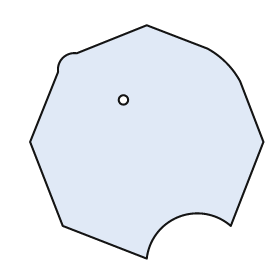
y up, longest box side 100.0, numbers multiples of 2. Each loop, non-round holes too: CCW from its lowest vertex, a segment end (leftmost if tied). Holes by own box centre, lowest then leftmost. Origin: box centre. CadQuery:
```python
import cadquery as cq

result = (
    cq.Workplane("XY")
    .moveTo(0.0, -50.0)
    .threePointArc((14.0, -32.0), (36.0, -36.0))
    .lineTo(50.0, 0.0)
    .lineTo(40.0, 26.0)
    .threePointArc((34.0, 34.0), (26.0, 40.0))
    .lineTo(0.0, 50.0)
    .lineTo(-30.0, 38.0)
    .threePointArc((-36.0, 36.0), (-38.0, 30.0))
    .lineTo(-50.0, 0.0)
    .lineTo(-36.0, -36.0)
    .close()
    .moveTo(-10.0, 18.0)
    .circle(2.0)
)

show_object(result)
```